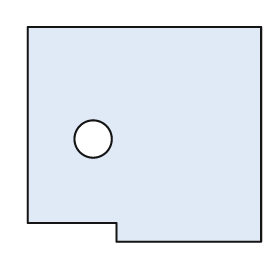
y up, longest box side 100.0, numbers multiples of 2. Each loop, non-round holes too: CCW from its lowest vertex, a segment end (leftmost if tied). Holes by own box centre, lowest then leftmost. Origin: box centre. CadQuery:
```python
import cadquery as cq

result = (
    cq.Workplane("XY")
    .moveTo(-12.0, -46.0)
    .lineTo(50.0, -46.0)
    .lineTo(50.0, 46.0)
    .lineTo(-50.0, 46.0)
    .lineTo(-50.0, -38.0)
    .lineTo(-12.0, -38.0)
    .close()
    .moveTo(-22.0, -2.0)
    .circle(8.0)
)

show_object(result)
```